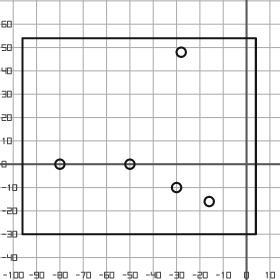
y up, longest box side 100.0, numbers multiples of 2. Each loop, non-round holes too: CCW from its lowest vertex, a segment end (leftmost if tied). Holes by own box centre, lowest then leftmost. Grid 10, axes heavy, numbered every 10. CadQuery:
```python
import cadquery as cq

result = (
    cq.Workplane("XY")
    .moveTo(-96.0, -30.0)
    .lineTo(4.0, -30.0)
    .lineTo(4.0, 54.0)
    .lineTo(-96.0, 54.0)
    .close()
    .moveTo(-16.0, -16.0)
    .circle(2.0)
    .moveTo(-30.0, -10.0)
    .circle(2.0)
    .moveTo(-80.0, 0.0)
    .circle(2.0)
    .moveTo(-50.0, 0.0)
    .circle(2.0)
    .moveTo(-28.0, 48.0)
    .circle(2.0)
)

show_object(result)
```